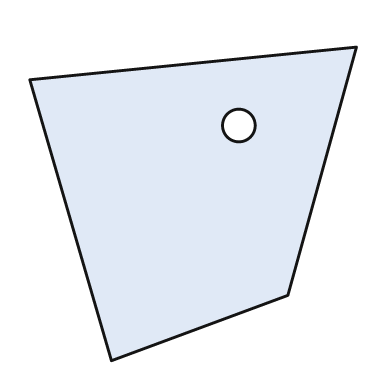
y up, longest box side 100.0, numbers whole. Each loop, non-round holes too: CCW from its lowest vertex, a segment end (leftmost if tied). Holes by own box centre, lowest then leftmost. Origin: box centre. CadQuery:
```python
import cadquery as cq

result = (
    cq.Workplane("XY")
    .moveTo(-25.0, -48.0)
    .lineTo(29.0, -28.0)
    .lineTo(50.0, 48.0)
    .lineTo(-50.0, 38.0)
    .close()
    .moveTo(14.0, 24.0)
    .circle(5.0)
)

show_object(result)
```